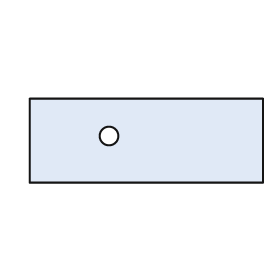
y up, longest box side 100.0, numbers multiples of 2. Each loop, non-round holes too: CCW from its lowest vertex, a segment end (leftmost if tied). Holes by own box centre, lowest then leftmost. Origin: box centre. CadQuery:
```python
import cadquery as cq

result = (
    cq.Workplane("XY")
    .moveTo(-50.0, -18.0)
    .lineTo(50.0, -18.0)
    .lineTo(50.0, 18.0)
    .lineTo(-50.0, 18.0)
    .close()
    .moveTo(-16.0, 2.0)
    .circle(4.0)
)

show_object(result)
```